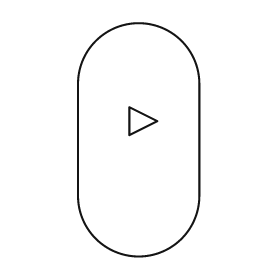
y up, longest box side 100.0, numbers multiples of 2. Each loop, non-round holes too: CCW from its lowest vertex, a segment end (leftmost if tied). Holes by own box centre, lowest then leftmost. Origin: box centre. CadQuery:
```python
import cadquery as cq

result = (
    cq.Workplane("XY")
    .moveTo(-26.0, -24.0)
    .threePointArc((0.0, -50.0), (26.0, -24.0))
    .lineTo(26.0, 24.0)
    .threePointArc((0.0, 50.0), (-26.0, 24.0))
    .close()
    .moveTo(-4.0, 2.0)
    .lineTo(8.0, 8.0)
    .lineTo(-4.0, 14.0)
    .close()
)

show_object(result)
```